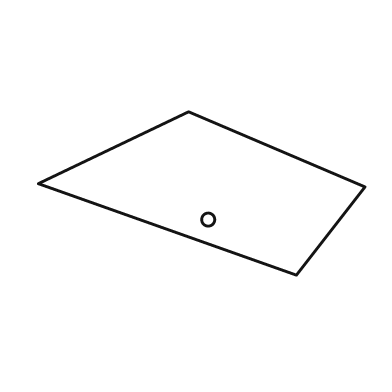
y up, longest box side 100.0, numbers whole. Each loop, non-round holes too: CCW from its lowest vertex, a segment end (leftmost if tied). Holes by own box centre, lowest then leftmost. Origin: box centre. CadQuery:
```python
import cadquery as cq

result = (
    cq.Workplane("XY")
    .moveTo(29.0, -25.0)
    .lineTo(50.0, 2.0)
    .lineTo(-4.0, 25.0)
    .lineTo(-50.0, 3.0)
    .close()
    .moveTo(2.0, -8.0)
    .circle(2.0)
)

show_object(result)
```